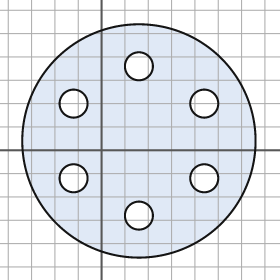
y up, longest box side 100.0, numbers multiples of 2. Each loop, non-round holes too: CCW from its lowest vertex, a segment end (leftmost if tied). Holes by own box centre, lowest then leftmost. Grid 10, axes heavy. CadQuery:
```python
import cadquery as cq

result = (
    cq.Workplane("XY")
    .moveTo(16.0, 4.0)
    .circle(50.0)
    .moveTo(16.0, -28.0)
    .circle(6.0)
    .moveTo(-12.0, -12.0)
    .circle(6.0)
    .moveTo(44.0, -12.0)
    .circle(6.0)
    .moveTo(-12.0, 20.0)
    .circle(6.0)
    .moveTo(44.0, 20.0)
    .circle(6.0)
    .moveTo(16.0, 36.0)
    .circle(6.0)
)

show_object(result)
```